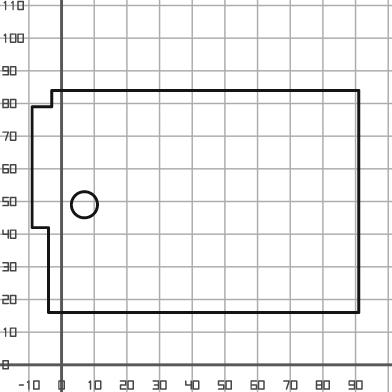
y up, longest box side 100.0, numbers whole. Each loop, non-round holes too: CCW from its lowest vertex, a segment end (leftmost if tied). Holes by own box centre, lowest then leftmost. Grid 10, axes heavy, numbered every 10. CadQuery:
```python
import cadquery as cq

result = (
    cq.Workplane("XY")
    .moveTo(-4.0, 16.0)
    .lineTo(91.0, 16.0)
    .lineTo(91.0, 84.0)
    .lineTo(-3.0, 84.0)
    .lineTo(-3.0, 79.0)
    .lineTo(-9.0, 79.0)
    .lineTo(-9.0, 42.0)
    .lineTo(-4.0, 42.0)
    .close()
    .moveTo(7.0, 49.0)
    .circle(4.0)
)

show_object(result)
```